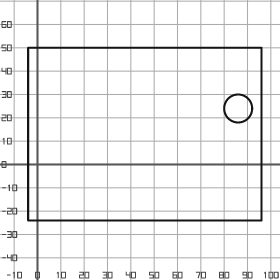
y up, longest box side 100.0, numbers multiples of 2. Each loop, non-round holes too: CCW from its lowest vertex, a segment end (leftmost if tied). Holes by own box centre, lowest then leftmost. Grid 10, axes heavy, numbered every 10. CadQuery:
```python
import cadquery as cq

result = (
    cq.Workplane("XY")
    .moveTo(-4.0, -24.0)
    .lineTo(96.0, -24.0)
    .lineTo(96.0, 50.0)
    .lineTo(-4.0, 50.0)
    .close()
    .moveTo(86.0, 24.0)
    .circle(6.0)
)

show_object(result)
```